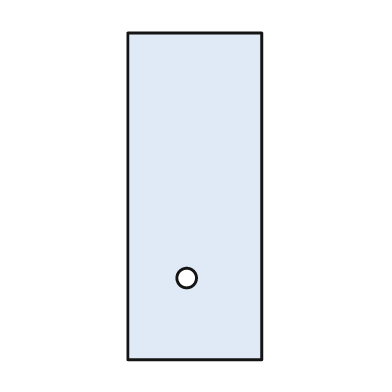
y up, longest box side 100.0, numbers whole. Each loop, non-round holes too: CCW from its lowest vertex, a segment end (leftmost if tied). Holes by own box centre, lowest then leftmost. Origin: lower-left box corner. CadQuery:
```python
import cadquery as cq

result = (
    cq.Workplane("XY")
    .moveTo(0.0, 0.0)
    .lineTo(41.0, 0.0)
    .lineTo(41.0, 100.0)
    .lineTo(0.0, 100.0)
    .close()
    .moveTo(18.0, 25.0)
    .circle(3.0)
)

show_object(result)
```